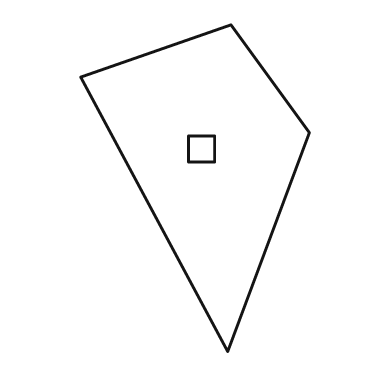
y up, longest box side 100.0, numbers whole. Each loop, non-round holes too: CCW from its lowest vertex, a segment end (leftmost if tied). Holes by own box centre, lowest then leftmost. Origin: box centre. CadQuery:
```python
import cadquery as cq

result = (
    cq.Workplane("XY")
    .moveTo(10.0, -50.0)
    .lineTo(35.0, 17.0)
    .lineTo(11.0, 50.0)
    .lineTo(-35.0, 34.0)
    .close()
    .moveTo(-2.0, 8.0)
    .lineTo(6.0, 8.0)
    .lineTo(6.0, 16.0)
    .lineTo(-2.0, 16.0)
    .close()
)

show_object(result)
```